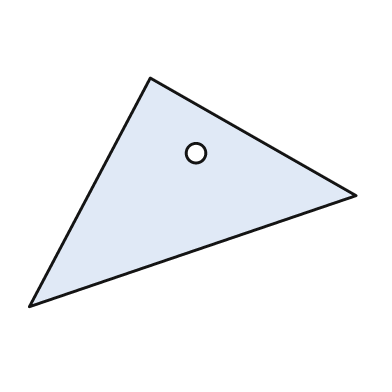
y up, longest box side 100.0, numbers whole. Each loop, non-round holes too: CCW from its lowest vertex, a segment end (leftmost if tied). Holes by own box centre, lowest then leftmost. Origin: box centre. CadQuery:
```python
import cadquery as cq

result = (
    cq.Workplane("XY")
    .moveTo(-50.0, -35.0)
    .lineTo(50.0, -1.0)
    .lineTo(-13.0, 35.0)
    .close()
    .moveTo(1.0, 12.0)
    .circle(3.0)
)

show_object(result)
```